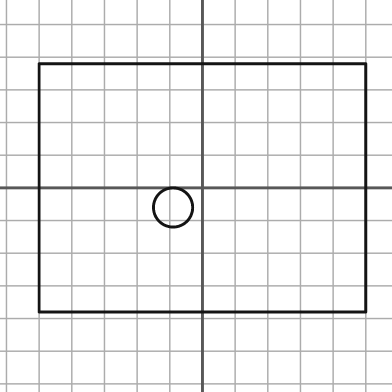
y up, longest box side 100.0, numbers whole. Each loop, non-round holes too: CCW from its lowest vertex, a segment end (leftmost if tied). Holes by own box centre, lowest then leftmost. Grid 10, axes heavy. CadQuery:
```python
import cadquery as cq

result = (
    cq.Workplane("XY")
    .moveTo(-50.0, -38.0)
    .lineTo(50.0, -38.0)
    .lineTo(50.0, 38.0)
    .lineTo(-50.0, 38.0)
    .close()
    .moveTo(-9.0, -6.0)
    .circle(6.0)
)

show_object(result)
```